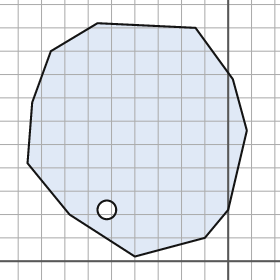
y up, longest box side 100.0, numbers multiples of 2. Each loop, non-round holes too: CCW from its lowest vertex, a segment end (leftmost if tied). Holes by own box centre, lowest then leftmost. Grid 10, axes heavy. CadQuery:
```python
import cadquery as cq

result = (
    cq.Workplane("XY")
    .moveTo(-40.0, 2.0)
    .lineTo(-10.0, 10.0)
    .lineTo(0.0, 22.0)
    .lineTo(8.0, 56.0)
    .lineTo(2.0, 78.0)
    .lineTo(-14.0, 100.0)
    .lineTo(-56.0, 102.0)
    .lineTo(-76.0, 90.0)
    .lineTo(-84.0, 68.0)
    .lineTo(-86.0, 42.0)
    .lineTo(-68.0, 20.0)
    .close()
    .moveTo(-52.0, 22.0)
    .circle(4.0)
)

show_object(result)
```